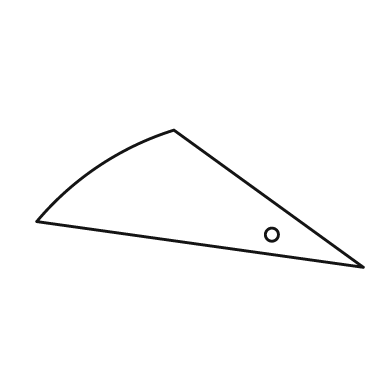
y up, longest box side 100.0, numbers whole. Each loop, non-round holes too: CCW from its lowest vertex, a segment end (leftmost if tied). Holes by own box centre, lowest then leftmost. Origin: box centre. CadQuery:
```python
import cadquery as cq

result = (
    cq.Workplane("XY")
    .moveTo(50.0, -21.0)
    .lineTo(-8.0, 21.0)
    .threePointArc((-31.0, 10.0), (-50.0, -7.0))
    .close()
    .moveTo(22.0, -11.0)
    .circle(2.0)
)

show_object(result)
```